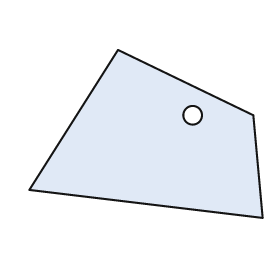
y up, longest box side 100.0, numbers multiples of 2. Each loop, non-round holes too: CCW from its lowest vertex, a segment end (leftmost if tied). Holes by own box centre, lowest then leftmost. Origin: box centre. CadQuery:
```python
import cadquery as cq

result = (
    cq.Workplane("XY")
    .moveTo(50.0, -36.0)
    .lineTo(46.0, 8.0)
    .lineTo(-12.0, 36.0)
    .lineTo(-50.0, -24.0)
    .close()
    .moveTo(20.0, 8.0)
    .circle(4.0)
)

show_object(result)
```